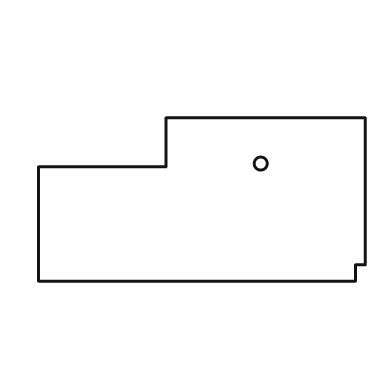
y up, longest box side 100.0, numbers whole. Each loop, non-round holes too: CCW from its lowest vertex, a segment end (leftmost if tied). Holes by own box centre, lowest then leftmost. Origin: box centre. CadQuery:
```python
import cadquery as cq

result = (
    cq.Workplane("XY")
    .moveTo(-50.0, -25.0)
    .lineTo(47.0, -25.0)
    .lineTo(47.0, -20.0)
    .lineTo(50.0, -20.0)
    .lineTo(50.0, 25.0)
    .lineTo(-11.0, 25.0)
    .lineTo(-11.0, 10.0)
    .lineTo(-50.0, 10.0)
    .close()
    .moveTo(18.0, 11.0)
    .circle(2.0)
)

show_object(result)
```